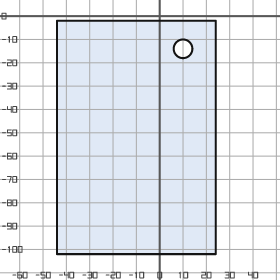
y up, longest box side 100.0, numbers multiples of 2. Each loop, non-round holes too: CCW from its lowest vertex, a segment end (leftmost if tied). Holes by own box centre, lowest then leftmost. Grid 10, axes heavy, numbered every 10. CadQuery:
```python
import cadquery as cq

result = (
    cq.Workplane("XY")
    .moveTo(-44.0, -102.0)
    .lineTo(24.0, -102.0)
    .lineTo(24.0, -2.0)
    .lineTo(-44.0, -2.0)
    .close()
    .moveTo(10.0, -14.0)
    .circle(4.0)
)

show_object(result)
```